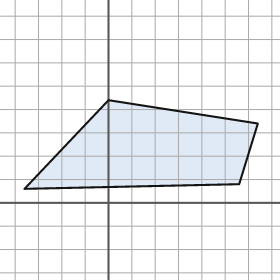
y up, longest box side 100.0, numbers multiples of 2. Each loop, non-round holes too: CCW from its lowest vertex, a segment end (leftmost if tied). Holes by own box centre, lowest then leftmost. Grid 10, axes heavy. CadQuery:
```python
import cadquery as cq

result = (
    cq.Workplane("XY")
    .moveTo(-36.0, 6.0)
    .lineTo(56.0, 8.0)
    .lineTo(64.0, 34.0)
    .lineTo(0.0, 44.0)
    .close()
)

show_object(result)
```